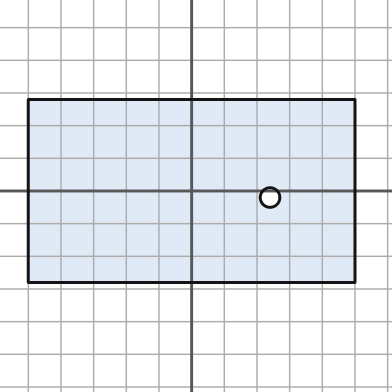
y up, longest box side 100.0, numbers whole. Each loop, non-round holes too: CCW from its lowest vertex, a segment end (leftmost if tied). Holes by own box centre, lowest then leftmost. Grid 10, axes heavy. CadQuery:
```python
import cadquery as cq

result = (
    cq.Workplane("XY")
    .moveTo(-50.0, -28.0)
    .lineTo(50.0, -28.0)
    .lineTo(50.0, 28.0)
    .lineTo(-50.0, 28.0)
    .close()
    .moveTo(24.0, -2.0)
    .circle(3.0)
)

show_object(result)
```